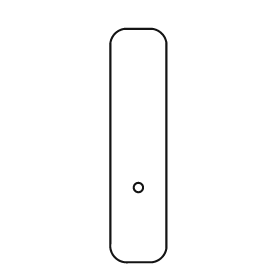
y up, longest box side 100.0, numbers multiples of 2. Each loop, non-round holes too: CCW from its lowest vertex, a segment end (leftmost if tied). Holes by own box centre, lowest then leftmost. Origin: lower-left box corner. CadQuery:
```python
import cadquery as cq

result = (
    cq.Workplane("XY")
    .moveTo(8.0, 0.0)
    .lineTo(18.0, 0.0)
    .threePointArc((22.0, 2.0), (24.0, 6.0))
    .lineTo(24.0, 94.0)
    .threePointArc((22.0, 98.0), (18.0, 100.0))
    .lineTo(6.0, 100.0)
    .threePointArc((2.0, 98.0), (0.0, 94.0))
    .lineTo(0.0, 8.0)
    .threePointArc((2.0, 2.0), (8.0, 0.0))
    .close()
    .moveTo(12.0, 32.0)
    .circle(2.0)
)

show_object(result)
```